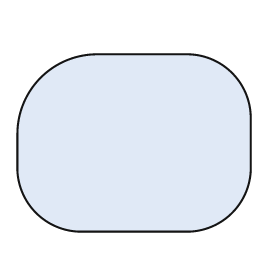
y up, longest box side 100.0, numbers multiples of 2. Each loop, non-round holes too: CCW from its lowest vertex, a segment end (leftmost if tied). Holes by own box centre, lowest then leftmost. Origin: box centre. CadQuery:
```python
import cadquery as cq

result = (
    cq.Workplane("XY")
    .moveTo(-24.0, -38.0)
    .lineTo(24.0, -38.0)
    .threePointArc((42.0, -30.0), (50.0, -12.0))
    .lineTo(50.0, 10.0)
    .threePointArc((42.0, 30.0), (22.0, 38.0))
    .lineTo(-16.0, 38.0)
    .threePointArc((-40.0, 28.0), (-50.0, 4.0))
    .lineTo(-50.0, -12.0)
    .threePointArc((-42.0, -30.0), (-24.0, -38.0))
    .close()
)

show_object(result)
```